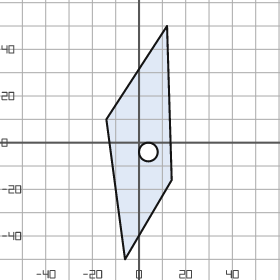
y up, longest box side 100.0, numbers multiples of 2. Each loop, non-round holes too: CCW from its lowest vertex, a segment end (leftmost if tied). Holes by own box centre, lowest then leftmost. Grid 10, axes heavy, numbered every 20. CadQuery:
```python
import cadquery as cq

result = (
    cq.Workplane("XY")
    .moveTo(-6.0, -50.0)
    .lineTo(14.0, -16.0)
    .lineTo(12.0, 50.0)
    .lineTo(-14.0, 10.0)
    .close()
    .moveTo(4.0, -4.0)
    .circle(4.0)
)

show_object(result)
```